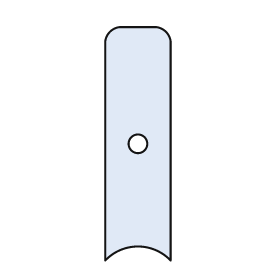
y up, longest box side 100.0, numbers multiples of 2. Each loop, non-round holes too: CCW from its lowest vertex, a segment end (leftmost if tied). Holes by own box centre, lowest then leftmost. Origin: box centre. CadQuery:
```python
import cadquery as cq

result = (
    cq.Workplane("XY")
    .moveTo(-14.0, -50.0)
    .threePointArc((0.0, -44.0), (14.0, -50.0))
    .lineTo(14.0, 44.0)
    .threePointArc((12.0, 48.0), (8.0, 50.0))
    .lineTo(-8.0, 50.0)
    .threePointArc((-12.0, 48.0), (-14.0, 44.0))
    .close()
    .moveTo(0.0, 0.0)
    .circle(4.0)
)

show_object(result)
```